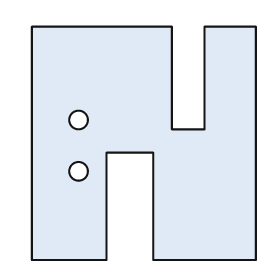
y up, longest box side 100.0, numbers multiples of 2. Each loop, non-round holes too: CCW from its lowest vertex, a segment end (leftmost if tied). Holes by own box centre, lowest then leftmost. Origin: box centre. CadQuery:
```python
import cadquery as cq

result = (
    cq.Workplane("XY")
    .moveTo(-48.0, -50.0)
    .lineTo(-16.0, -50.0)
    .lineTo(-16.0, -4.0)
    .lineTo(4.0, -4.0)
    .lineTo(4.0, -50.0)
    .lineTo(48.0, -50.0)
    .lineTo(48.0, 50.0)
    .lineTo(26.0, 50.0)
    .lineTo(26.0, 6.0)
    .lineTo(12.0, 6.0)
    .lineTo(12.0, 50.0)
    .lineTo(-48.0, 50.0)
    .close()
    .moveTo(-28.0, -12.0)
    .circle(4.0)
    .moveTo(-28.0, 10.0)
    .circle(4.0)
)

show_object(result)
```